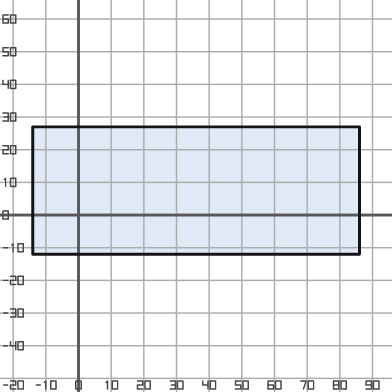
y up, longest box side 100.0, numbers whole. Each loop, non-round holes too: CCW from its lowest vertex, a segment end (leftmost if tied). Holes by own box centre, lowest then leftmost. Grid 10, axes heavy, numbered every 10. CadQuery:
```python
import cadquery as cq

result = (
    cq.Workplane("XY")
    .moveTo(-14.0, -12.0)
    .lineTo(86.0, -12.0)
    .lineTo(86.0, 27.0)
    .lineTo(-14.0, 27.0)
    .close()
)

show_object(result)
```